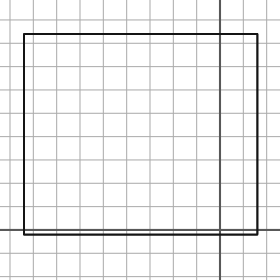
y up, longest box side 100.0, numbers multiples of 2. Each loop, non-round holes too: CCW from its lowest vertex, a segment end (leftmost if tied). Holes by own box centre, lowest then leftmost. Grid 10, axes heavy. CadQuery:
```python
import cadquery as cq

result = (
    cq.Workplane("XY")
    .moveTo(-84.0, -2.0)
    .lineTo(16.0, -2.0)
    .lineTo(16.0, 84.0)
    .lineTo(-84.0, 84.0)
    .close()
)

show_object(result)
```